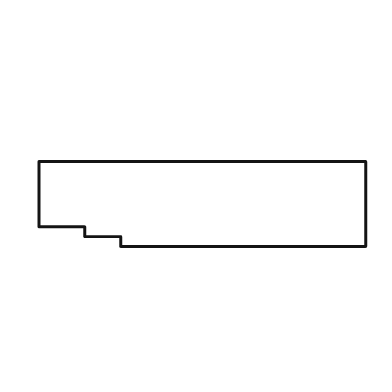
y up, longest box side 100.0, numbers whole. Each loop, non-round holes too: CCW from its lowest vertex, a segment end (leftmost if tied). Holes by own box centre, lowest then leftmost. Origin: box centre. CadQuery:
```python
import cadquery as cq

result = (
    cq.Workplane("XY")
    .moveTo(-25.0, -13.0)
    .lineTo(50.0, -13.0)
    .lineTo(50.0, 13.0)
    .lineTo(-50.0, 13.0)
    .lineTo(-50.0, -7.0)
    .lineTo(-36.0, -7.0)
    .lineTo(-36.0, -10.0)
    .lineTo(-25.0, -10.0)
    .close()
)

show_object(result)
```